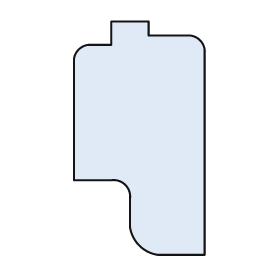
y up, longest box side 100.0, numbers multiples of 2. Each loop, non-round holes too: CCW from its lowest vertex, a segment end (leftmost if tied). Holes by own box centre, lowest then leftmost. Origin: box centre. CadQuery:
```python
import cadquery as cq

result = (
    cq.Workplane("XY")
    .moveTo(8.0, -50.0)
    .lineTo(28.0, -50.0)
    .lineTo(28.0, 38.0)
    .threePointArc((26.0, 42.0), (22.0, 44.0))
    .lineTo(4.0, 44.0)
    .lineTo(4.0, 50.0)
    .lineTo(-12.0, 50.0)
    .lineTo(-12.0, 40.0)
    .lineTo(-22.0, 40.0)
    .threePointArc((-26.0, 38.0), (-28.0, 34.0))
    .lineTo(-28.0, -18.0)
    .lineTo(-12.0, -18.0)
    .threePointArc((-6.0, -20.0), (-4.0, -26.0))
    .lineTo(-4.0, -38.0)
    .threePointArc((0.0, -46.0), (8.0, -50.0))
    .close()
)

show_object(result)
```